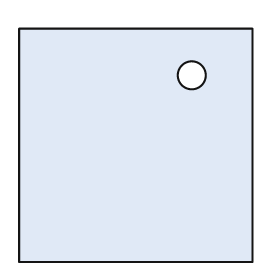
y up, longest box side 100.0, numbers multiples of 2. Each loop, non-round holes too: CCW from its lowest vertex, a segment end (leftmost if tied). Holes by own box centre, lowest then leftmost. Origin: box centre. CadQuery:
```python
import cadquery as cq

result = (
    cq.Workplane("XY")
    .moveTo(-50.0, -50.0)
    .lineTo(50.0, -50.0)
    .lineTo(50.0, 50.0)
    .lineTo(-50.0, 50.0)
    .close()
    .moveTo(24.0, 30.0)
    .circle(6.0)
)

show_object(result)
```